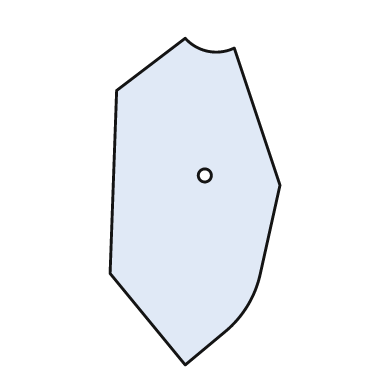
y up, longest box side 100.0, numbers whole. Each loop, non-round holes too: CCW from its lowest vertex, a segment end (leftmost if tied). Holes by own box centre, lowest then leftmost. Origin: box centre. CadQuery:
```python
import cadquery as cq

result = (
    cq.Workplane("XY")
    .moveTo(-3.0, -50.0)
    .lineTo(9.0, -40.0)
    .threePointArc((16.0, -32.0), (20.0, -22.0))
    .lineTo(26.0, 5.0)
    .lineTo(12.0, 47.0)
    .threePointArc((4.0, 46.0), (-3.0, 50.0))
    .lineTo(-24.0, 34.0)
    .lineTo(-26.0, -22.0)
    .close()
    .moveTo(3.0, 8.0)
    .circle(2.0)
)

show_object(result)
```